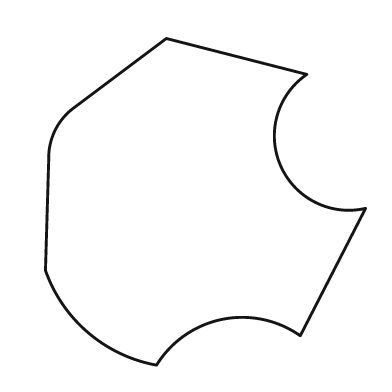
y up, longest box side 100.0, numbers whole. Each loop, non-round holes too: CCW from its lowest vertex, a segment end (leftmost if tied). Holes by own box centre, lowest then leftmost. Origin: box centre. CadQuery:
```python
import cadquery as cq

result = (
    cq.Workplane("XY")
    .moveTo(-15.0, -50.0)
    .threePointArc((5.0, -36.0), (29.0, -41.0))
    .lineTo(49.0, -2.0)
    .threePointArc((23.0, 11.0), (31.0, 39.0))
    .lineTo(-12.0, 50.0)
    .lineTo(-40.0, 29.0)
    .threePointArc((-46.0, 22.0), (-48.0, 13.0))
    .lineTo(-49.0, -21.0)
    .threePointArc((-36.0, -40.0), (-15.0, -50.0))
    .close()
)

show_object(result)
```